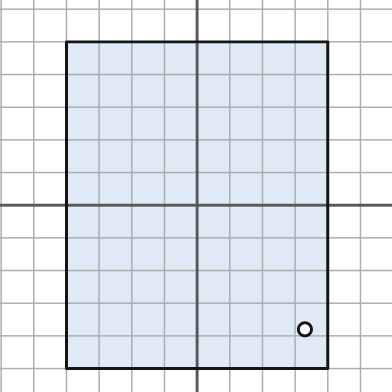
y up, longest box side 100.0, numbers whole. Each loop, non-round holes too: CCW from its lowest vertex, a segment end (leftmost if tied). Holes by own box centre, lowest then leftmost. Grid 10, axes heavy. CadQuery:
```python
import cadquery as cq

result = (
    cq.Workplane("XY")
    .moveTo(-40.0, -50.0)
    .lineTo(40.0, -50.0)
    .lineTo(40.0, 50.0)
    .lineTo(-40.0, 50.0)
    .close()
    .moveTo(33.0, -38.0)
    .circle(2.0)
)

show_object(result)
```